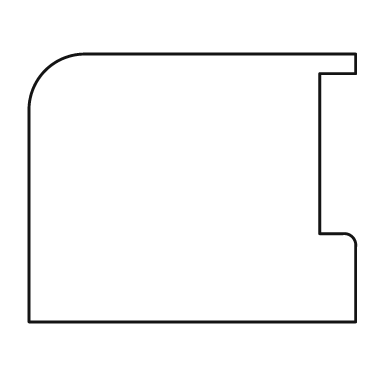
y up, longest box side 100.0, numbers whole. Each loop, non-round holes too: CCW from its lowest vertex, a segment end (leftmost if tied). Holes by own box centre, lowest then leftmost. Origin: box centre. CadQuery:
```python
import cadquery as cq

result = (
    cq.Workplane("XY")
    .moveTo(-50.0, -41.0)
    .lineTo(50.0, -41.0)
    .lineTo(50.0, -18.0)
    .threePointArc((49.0, -15.0), (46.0, -14.0))
    .lineTo(39.0, -14.0)
    .lineTo(39.0, 35.0)
    .lineTo(50.0, 35.0)
    .lineTo(50.0, 41.0)
    .lineTo(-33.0, 41.0)
    .threePointArc((-45.0, 36.0), (-50.0, 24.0))
    .close()
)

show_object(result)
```